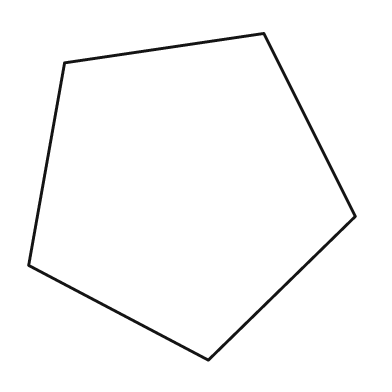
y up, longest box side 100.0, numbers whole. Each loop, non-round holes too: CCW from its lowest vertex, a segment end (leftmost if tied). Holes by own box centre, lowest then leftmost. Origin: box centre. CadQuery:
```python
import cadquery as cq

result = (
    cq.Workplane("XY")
    .moveTo(5.0, -50.0)
    .lineTo(50.0, -6.0)
    .lineTo(22.0, 50.0)
    .lineTo(-39.0, 41.0)
    .lineTo(-50.0, -21.0)
    .close()
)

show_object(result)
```